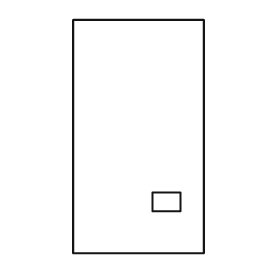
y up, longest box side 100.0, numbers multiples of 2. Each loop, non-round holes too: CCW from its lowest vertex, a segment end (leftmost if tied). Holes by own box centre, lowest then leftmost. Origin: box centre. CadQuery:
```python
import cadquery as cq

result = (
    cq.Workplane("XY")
    .moveTo(-28.0, -50.0)
    .lineTo(28.0, -50.0)
    .lineTo(28.0, 50.0)
    .lineTo(-28.0, 50.0)
    .close()
    .moveTo(6.0, -32.0)
    .lineTo(18.0, -32.0)
    .lineTo(18.0, -24.0)
    .lineTo(6.0, -24.0)
    .close()
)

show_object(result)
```